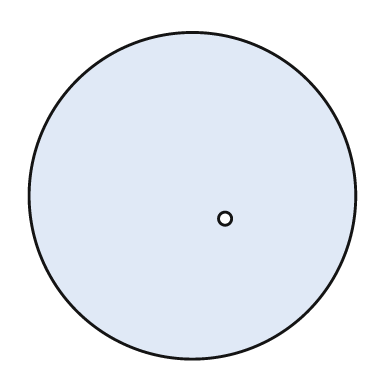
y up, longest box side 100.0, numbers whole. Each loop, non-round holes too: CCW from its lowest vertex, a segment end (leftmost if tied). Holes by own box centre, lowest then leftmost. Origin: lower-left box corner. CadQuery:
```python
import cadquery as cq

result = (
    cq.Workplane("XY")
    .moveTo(50.0, 50.0)
    .circle(50.0)
    .moveTo(60.0, 43.0)
    .circle(2.0)
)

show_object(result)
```